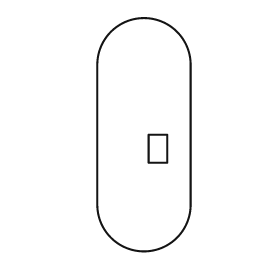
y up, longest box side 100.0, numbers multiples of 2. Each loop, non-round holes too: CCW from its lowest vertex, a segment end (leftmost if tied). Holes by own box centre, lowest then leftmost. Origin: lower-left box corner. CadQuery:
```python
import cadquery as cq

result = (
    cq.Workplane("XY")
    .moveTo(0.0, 20.0)
    .threePointArc((20.0, 0.0), (40.0, 20.0))
    .lineTo(40.0, 80.0)
    .threePointArc((20.0, 100.0), (0.0, 80.0))
    .close()
    .moveTo(22.0, 38.0)
    .lineTo(30.0, 38.0)
    .lineTo(30.0, 50.0)
    .lineTo(22.0, 50.0)
    .close()
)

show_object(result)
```